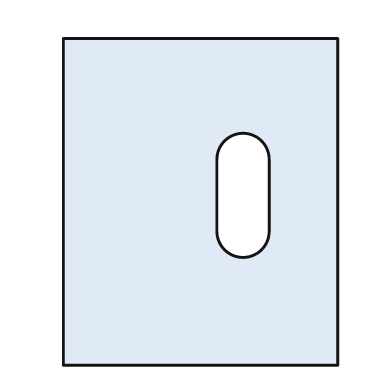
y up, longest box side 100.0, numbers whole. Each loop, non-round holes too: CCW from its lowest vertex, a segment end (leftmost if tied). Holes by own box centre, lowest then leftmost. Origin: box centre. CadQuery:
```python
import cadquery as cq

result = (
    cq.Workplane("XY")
    .moveTo(-42.0, -50.0)
    .lineTo(42.0, -50.0)
    .lineTo(42.0, 50.0)
    .lineTo(-42.0, 50.0)
    .close()
    .moveTo(5.0, -9.0)
    .threePointArc((13.0, -17.0), (21.0, -9.0))
    .lineTo(21.0, 13.0)
    .threePointArc((13.0, 21.0), (5.0, 13.0))
    .close()
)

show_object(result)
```